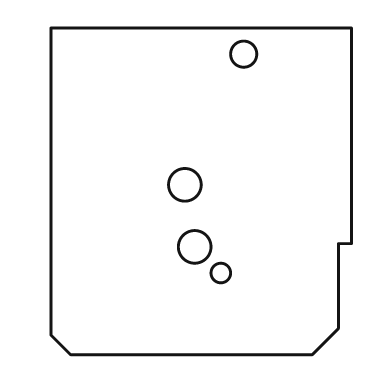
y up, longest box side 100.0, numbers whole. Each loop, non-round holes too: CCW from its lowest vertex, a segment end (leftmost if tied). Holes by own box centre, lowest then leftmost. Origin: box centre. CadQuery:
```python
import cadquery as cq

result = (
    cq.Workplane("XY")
    .moveTo(-40.0, -50.0)
    .lineTo(34.0, -50.0)
    .lineTo(42.0, -42.0)
    .lineTo(42.0, -16.0)
    .lineTo(46.0, -16.0)
    .lineTo(46.0, 50.0)
    .lineTo(-46.0, 50.0)
    .lineTo(-46.0, -44.0)
    .close()
    .moveTo(6.0, -25.0)
    .circle(3.0)
    .moveTo(-2.0, -17.0)
    .circle(5.0)
    .moveTo(-5.0, 2.0)
    .circle(5.0)
    .moveTo(13.0, 42.0)
    .circle(4.0)
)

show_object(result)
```